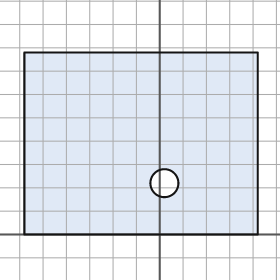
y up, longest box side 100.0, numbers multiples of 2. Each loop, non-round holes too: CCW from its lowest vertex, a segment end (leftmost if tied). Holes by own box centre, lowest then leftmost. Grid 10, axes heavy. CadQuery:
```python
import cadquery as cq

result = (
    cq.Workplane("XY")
    .moveTo(-58.0, 0.0)
    .lineTo(42.0, 0.0)
    .lineTo(42.0, 78.0)
    .lineTo(-58.0, 78.0)
    .close()
    .moveTo(2.0, 22.0)
    .circle(6.0)
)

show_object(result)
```